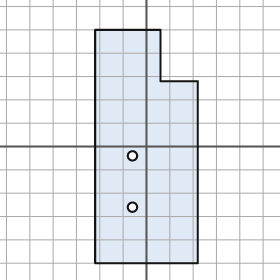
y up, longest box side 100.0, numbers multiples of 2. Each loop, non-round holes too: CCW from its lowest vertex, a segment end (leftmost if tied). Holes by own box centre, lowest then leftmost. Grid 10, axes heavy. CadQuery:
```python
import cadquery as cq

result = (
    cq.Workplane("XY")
    .moveTo(-22.0, -50.0)
    .lineTo(22.0, -50.0)
    .lineTo(22.0, 28.0)
    .lineTo(6.0, 28.0)
    .lineTo(6.0, 50.0)
    .lineTo(-22.0, 50.0)
    .close()
    .moveTo(-6.0, -26.0)
    .circle(2.0)
    .moveTo(-6.0, -4.0)
    .circle(2.0)
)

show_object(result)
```